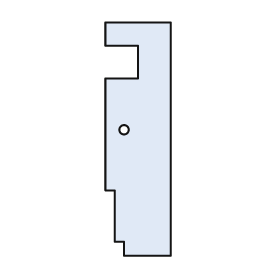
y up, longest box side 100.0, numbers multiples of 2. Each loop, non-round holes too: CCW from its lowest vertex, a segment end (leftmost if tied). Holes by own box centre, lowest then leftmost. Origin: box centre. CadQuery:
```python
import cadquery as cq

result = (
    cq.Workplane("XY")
    .moveTo(-6.0, -50.0)
    .lineTo(14.0, -50.0)
    .lineTo(14.0, 50.0)
    .lineTo(-14.0, 50.0)
    .lineTo(-14.0, 40.0)
    .lineTo(0.0, 40.0)
    .lineTo(0.0, 26.0)
    .lineTo(-14.0, 26.0)
    .lineTo(-14.0, -22.0)
    .lineTo(-10.0, -22.0)
    .lineTo(-10.0, -44.0)
    .lineTo(-6.0, -44.0)
    .close()
    .moveTo(-6.0, 4.0)
    .circle(2.0)
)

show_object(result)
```